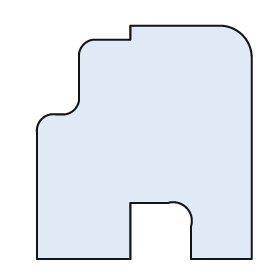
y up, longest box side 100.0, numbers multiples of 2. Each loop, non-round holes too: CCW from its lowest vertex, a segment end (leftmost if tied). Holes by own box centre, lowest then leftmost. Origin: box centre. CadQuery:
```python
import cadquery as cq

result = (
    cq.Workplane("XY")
    .moveTo(-46.0, -50.0)
    .lineTo(-6.0, -50.0)
    .lineTo(-6.0, -26.0)
    .lineTo(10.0, -26.0)
    .threePointArc((18.0, -28.0), (20.0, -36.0))
    .lineTo(20.0, -50.0)
    .lineTo(46.0, -50.0)
    .lineTo(46.0, 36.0)
    .threePointArc((42.0, 46.0), (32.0, 50.0))
    .lineTo(-6.0, 50.0)
    .lineTo(-6.0, 44.0)
    .lineTo(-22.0, 44.0)
    .threePointArc((-26.0, 42.0), (-28.0, 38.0))
    .lineTo(-28.0, 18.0)
    .threePointArc((-30.0, 14.0), (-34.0, 12.0))
    .lineTo(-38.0, 12.0)
    .threePointArc((-44.0, 10.0), (-46.0, 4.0))
    .close()
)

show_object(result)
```